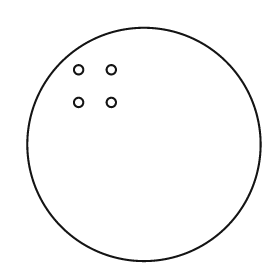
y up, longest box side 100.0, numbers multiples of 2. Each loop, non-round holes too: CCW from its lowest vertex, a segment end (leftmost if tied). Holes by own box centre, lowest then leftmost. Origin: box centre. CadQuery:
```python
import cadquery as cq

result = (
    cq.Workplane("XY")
    .moveTo(0.0, 0.0)
    .circle(50.0)
    .moveTo(-28.0, 18.0)
    .circle(2.0)
    .moveTo(-14.0, 18.0)
    .circle(2.0)
    .moveTo(-28.0, 32.0)
    .circle(2.0)
    .moveTo(-14.0, 32.0)
    .circle(2.0)
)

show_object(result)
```